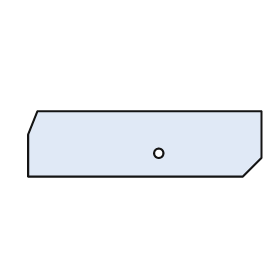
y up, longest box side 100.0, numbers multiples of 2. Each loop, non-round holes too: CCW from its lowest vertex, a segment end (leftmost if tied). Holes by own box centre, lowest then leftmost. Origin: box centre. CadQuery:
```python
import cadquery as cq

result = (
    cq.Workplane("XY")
    .moveTo(-50.0, -14.0)
    .lineTo(42.0, -14.0)
    .lineTo(50.0, -6.0)
    .lineTo(50.0, 14.0)
    .lineTo(-46.0, 14.0)
    .lineTo(-50.0, 4.0)
    .close()
    .moveTo(6.0, -4.0)
    .circle(2.0)
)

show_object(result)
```